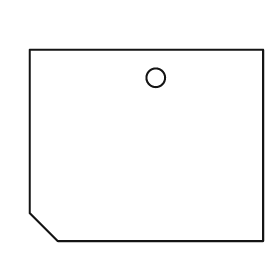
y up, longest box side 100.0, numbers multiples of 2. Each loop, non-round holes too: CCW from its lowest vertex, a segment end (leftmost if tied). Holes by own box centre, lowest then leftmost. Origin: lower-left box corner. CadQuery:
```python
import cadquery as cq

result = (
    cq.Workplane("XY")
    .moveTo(12.0, 0.0)
    .lineTo(100.0, 0.0)
    .lineTo(100.0, 82.0)
    .lineTo(0.0, 82.0)
    .lineTo(0.0, 12.0)
    .close()
    .moveTo(54.0, 70.0)
    .circle(4.0)
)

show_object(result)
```